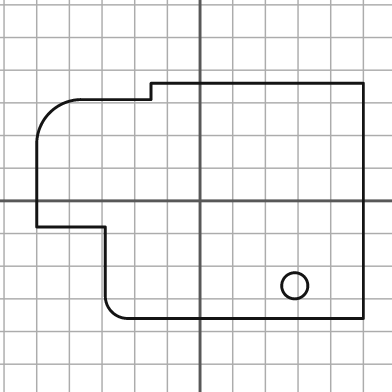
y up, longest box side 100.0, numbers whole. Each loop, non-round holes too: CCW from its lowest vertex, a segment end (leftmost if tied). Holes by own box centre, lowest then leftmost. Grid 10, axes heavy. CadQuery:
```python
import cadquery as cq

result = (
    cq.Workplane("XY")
    .moveTo(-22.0, -36.0)
    .lineTo(50.0, -36.0)
    .lineTo(50.0, 36.0)
    .lineTo(-15.0, 36.0)
    .lineTo(-15.0, 31.0)
    .lineTo(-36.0, 31.0)
    .threePointArc((-46.0, 27.0), (-50.0, 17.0))
    .lineTo(-50.0, -8.0)
    .lineTo(-29.0, -8.0)
    .lineTo(-29.0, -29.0)
    .threePointArc((-27.0, -34.0), (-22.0, -36.0))
    .close()
    .moveTo(29.0, -26.0)
    .circle(4.0)
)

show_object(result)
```